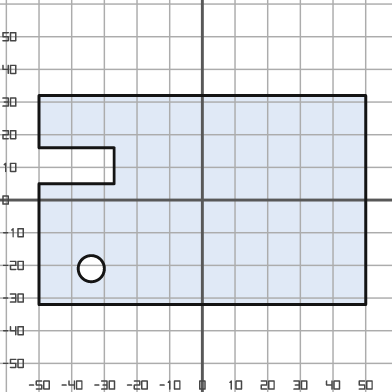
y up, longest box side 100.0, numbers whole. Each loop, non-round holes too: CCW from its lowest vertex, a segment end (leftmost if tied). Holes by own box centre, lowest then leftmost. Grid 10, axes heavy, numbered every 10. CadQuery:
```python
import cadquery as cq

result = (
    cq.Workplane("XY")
    .moveTo(-50.0, -32.0)
    .lineTo(50.0, -32.0)
    .lineTo(50.0, 32.0)
    .lineTo(-50.0, 32.0)
    .lineTo(-50.0, 16.0)
    .lineTo(-27.0, 16.0)
    .lineTo(-27.0, 5.0)
    .lineTo(-50.0, 5.0)
    .close()
    .moveTo(-34.0, -21.0)
    .circle(4.0)
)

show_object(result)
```